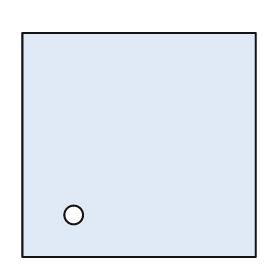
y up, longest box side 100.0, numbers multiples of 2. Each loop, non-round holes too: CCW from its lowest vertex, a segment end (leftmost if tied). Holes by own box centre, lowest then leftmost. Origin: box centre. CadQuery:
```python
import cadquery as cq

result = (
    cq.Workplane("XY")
    .moveTo(-50.0, -48.0)
    .lineTo(50.0, -48.0)
    .lineTo(50.0, 48.0)
    .lineTo(-50.0, 48.0)
    .close()
    .moveTo(-28.0, -30.0)
    .circle(4.0)
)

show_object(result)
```